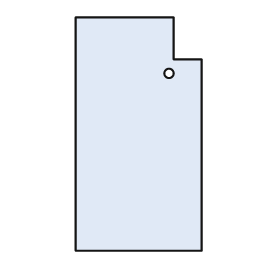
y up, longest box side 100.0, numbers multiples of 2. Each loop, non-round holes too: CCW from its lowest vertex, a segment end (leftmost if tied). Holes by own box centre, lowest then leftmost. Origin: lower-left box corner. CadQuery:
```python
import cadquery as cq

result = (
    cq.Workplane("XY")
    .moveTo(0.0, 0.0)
    .lineTo(54.0, 0.0)
    .lineTo(54.0, 82.0)
    .lineTo(42.0, 82.0)
    .lineTo(42.0, 100.0)
    .lineTo(0.0, 100.0)
    .close()
    .moveTo(40.0, 76.0)
    .circle(2.0)
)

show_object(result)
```